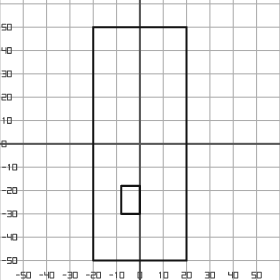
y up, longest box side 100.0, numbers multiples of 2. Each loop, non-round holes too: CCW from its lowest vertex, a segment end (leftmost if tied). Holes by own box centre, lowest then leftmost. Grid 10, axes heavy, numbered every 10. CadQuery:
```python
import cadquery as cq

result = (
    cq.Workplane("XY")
    .moveTo(-20.0, -50.0)
    .lineTo(20.0, -50.0)
    .lineTo(20.0, 50.0)
    .lineTo(-20.0, 50.0)
    .close()
    .moveTo(-8.0, -30.0)
    .lineTo(0.0, -30.0)
    .lineTo(0.0, -18.0)
    .lineTo(-8.0, -18.0)
    .close()
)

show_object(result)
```